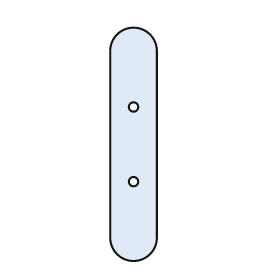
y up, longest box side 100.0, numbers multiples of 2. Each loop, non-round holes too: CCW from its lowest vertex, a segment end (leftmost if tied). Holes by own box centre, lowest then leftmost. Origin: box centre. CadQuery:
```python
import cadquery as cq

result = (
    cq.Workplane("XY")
    .moveTo(-10.0, -40.0)
    .threePointArc((0.0, -50.0), (10.0, -40.0))
    .lineTo(10.0, 40.0)
    .threePointArc((0.0, 50.0), (-10.0, 40.0))
    .close()
    .moveTo(0.0, -16.0)
    .circle(2.0)
    .moveTo(0.0, 16.0)
    .circle(2.0)
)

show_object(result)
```